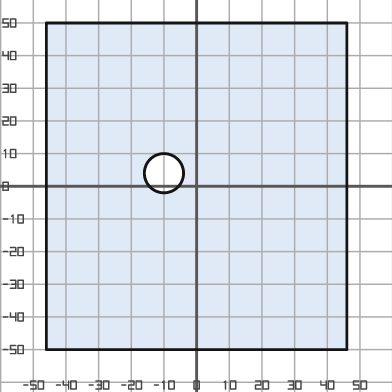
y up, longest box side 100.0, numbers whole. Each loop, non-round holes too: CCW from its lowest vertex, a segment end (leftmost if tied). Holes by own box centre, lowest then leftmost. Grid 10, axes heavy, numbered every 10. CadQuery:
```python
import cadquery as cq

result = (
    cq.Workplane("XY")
    .moveTo(-46.0, -50.0)
    .lineTo(46.0, -50.0)
    .lineTo(46.0, 50.0)
    .lineTo(-46.0, 50.0)
    .close()
    .moveTo(-10.0, 4.0)
    .circle(6.0)
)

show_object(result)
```